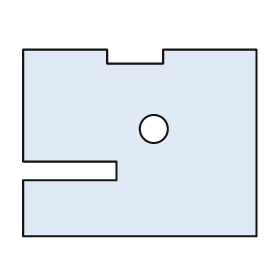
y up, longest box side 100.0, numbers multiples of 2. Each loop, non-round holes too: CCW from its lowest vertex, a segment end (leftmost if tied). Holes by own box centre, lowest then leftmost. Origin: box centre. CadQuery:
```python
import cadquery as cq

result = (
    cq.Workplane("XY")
    .moveTo(-50.0, -40.0)
    .lineTo(50.0, -40.0)
    .lineTo(50.0, 40.0)
    .lineTo(10.0, 40.0)
    .lineTo(10.0, 34.0)
    .lineTo(-14.0, 34.0)
    .lineTo(-14.0, 40.0)
    .lineTo(-50.0, 40.0)
    .lineTo(-50.0, -8.0)
    .lineTo(-10.0, -8.0)
    .lineTo(-10.0, -16.0)
    .lineTo(-50.0, -16.0)
    .close()
    .moveTo(6.0, 6.0)
    .circle(6.0)
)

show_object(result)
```